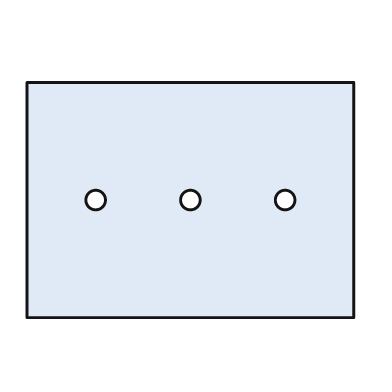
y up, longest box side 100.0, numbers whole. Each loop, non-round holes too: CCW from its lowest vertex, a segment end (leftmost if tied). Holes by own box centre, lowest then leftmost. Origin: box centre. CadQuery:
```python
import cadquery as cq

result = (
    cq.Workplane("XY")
    .moveTo(-50.0, -36.0)
    .lineTo(50.0, -36.0)
    .lineTo(50.0, 36.0)
    .lineTo(-50.0, 36.0)
    .close()
    .moveTo(-29.0, 0.0)
    .circle(3.0)
    .moveTo(0.0, 0.0)
    .circle(3.0)
    .moveTo(29.0, 0.0)
    .circle(3.0)
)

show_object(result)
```